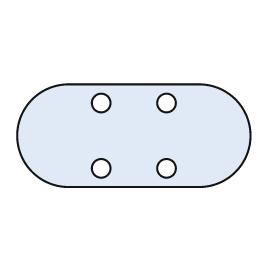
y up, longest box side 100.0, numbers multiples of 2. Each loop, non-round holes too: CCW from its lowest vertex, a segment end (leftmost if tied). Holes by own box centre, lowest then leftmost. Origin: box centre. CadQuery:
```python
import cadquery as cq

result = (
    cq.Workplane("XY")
    .moveTo(-28.0, -22.0)
    .lineTo(28.0, -22.0)
    .threePointArc((50.0, 0.0), (28.0, 22.0))
    .lineTo(-28.0, 22.0)
    .threePointArc((-50.0, 0.0), (-28.0, -22.0))
    .close()
    .moveTo(-14.0, -14.0)
    .circle(4.0)
    .moveTo(14.0, -14.0)
    .circle(4.0)
    .moveTo(-14.0, 14.0)
    .circle(4.0)
    .moveTo(14.0, 14.0)
    .circle(4.0)
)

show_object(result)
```